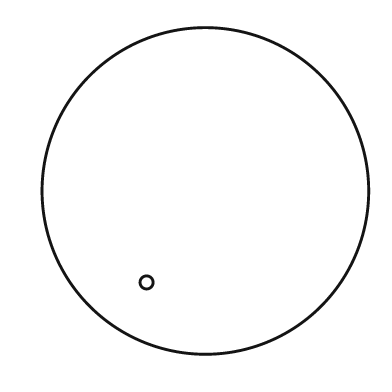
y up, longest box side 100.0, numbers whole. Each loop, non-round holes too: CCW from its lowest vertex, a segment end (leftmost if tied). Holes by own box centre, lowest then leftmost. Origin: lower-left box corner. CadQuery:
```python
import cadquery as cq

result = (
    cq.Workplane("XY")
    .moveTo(50.0, 50.0)
    .circle(50.0)
    .moveTo(32.0, 22.0)
    .circle(2.0)
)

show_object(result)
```